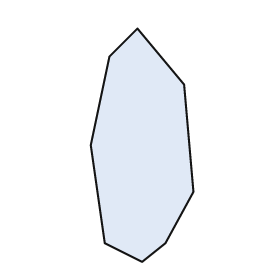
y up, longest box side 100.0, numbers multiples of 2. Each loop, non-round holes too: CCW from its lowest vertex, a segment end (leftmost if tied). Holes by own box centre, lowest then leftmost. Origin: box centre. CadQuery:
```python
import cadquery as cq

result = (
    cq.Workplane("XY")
    .moveTo(0.0, -50.0)
    .lineTo(10.0, -42.0)
    .lineTo(22.0, -20.0)
    .lineTo(18.0, 26.0)
    .lineTo(-2.0, 50.0)
    .lineTo(-14.0, 38.0)
    .lineTo(-22.0, 0.0)
    .lineTo(-16.0, -42.0)
    .close()
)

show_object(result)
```